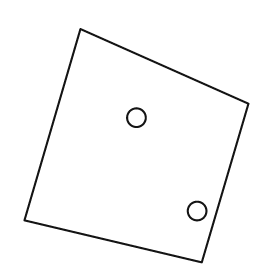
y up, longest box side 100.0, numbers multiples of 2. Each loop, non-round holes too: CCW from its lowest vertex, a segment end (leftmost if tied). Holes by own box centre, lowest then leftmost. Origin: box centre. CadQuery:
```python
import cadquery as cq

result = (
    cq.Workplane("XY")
    .moveTo(28.0, -50.0)
    .lineTo(48.0, 18.0)
    .lineTo(-24.0, 50.0)
    .lineTo(-48.0, -32.0)
    .close()
    .moveTo(26.0, -28.0)
    .circle(4.0)
    .moveTo(0.0, 12.0)
    .circle(4.0)
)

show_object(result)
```